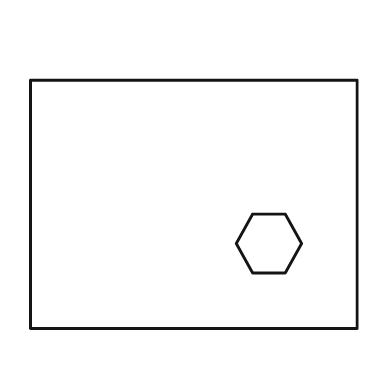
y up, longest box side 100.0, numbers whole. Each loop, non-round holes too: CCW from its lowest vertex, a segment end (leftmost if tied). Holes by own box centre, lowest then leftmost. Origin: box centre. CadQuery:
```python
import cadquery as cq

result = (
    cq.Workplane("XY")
    .moveTo(-50.0, -38.0)
    .lineTo(50.0, -38.0)
    .lineTo(50.0, 38.0)
    .lineTo(-50.0, 38.0)
    .close()
    .moveTo(18.0, -21.0)
    .lineTo(28.0, -21.0)
    .lineTo(33.0, -12.0)
    .lineTo(28.0, -3.0)
    .lineTo(18.0, -3.0)
    .lineTo(13.0, -12.0)
    .close()
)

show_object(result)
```